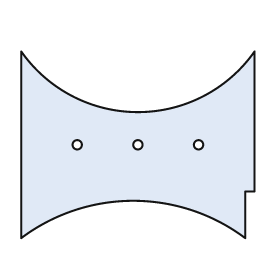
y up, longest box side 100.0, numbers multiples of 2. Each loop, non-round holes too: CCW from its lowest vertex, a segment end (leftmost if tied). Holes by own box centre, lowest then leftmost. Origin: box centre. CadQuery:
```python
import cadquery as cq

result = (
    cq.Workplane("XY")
    .moveTo(-50.0, -40.0)
    .threePointArc((-2.0, -24.0), (46.0, -40.0))
    .lineTo(46.0, -20.0)
    .lineTo(50.0, -20.0)
    .lineTo(50.0, 40.0)
    .threePointArc((0.0, 14.0), (-50.0, 40.0))
    .close()
    .moveTo(-26.0, 0.0)
    .circle(2.0)
    .moveTo(0.0, 0.0)
    .circle(2.0)
    .moveTo(26.0, 0.0)
    .circle(2.0)
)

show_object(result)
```